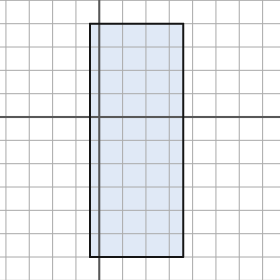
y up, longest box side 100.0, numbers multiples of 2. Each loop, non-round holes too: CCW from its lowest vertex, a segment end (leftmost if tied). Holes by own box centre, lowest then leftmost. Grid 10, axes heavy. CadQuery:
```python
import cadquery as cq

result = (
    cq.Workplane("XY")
    .moveTo(-4.0, -60.0)
    .lineTo(36.0, -60.0)
    .lineTo(36.0, 40.0)
    .lineTo(-4.0, 40.0)
    .close()
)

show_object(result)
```